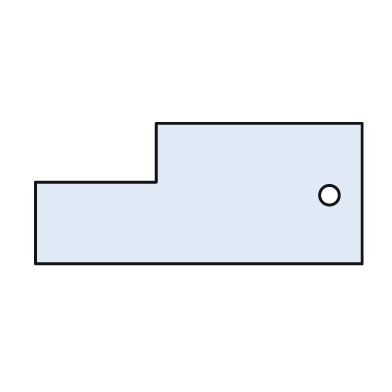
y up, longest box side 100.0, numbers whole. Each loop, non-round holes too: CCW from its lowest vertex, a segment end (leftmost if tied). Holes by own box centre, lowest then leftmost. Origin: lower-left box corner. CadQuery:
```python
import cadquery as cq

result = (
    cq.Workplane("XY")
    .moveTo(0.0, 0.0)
    .lineTo(100.0, 0.0)
    .lineTo(100.0, 43.0)
    .lineTo(37.0, 43.0)
    .lineTo(37.0, 25.0)
    .lineTo(0.0, 25.0)
    .close()
    .moveTo(90.0, 21.0)
    .circle(3.0)
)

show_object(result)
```